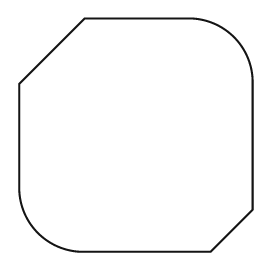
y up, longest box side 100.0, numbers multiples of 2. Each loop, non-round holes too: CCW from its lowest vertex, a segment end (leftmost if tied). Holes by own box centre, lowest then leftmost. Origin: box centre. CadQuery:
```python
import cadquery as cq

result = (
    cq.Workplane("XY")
    .moveTo(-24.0, -50.0)
    .lineTo(32.0, -50.0)
    .lineTo(50.0, -32.0)
    .lineTo(50.0, 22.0)
    .threePointArc((42.0, 42.0), (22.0, 50.0))
    .lineTo(-22.0, 50.0)
    .lineTo(-50.0, 22.0)
    .lineTo(-50.0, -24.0)
    .threePointArc((-42.0, -42.0), (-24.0, -50.0))
    .close()
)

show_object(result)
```